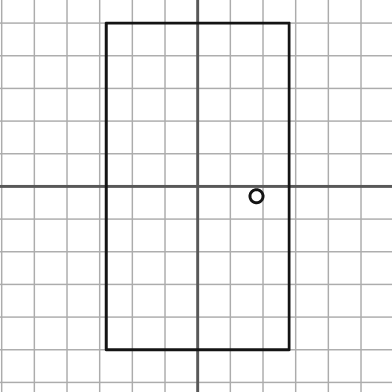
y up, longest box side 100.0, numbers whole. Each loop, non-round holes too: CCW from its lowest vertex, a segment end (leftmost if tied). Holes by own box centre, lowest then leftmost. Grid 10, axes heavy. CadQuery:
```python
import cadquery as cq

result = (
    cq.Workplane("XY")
    .moveTo(-28.0, -50.0)
    .lineTo(28.0, -50.0)
    .lineTo(28.0, 50.0)
    .lineTo(-28.0, 50.0)
    .close()
    .moveTo(18.0, -3.0)
    .circle(2.0)
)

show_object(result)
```